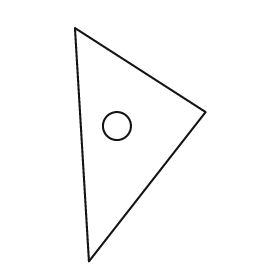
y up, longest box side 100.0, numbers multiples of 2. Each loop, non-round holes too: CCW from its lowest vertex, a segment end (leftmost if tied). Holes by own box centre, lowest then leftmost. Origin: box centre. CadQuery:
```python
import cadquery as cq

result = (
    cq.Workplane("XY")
    .moveTo(-22.0, -50.0)
    .lineTo(28.0, 14.0)
    .lineTo(-28.0, 50.0)
    .close()
    .moveTo(-10.0, 8.0)
    .circle(6.0)
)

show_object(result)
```